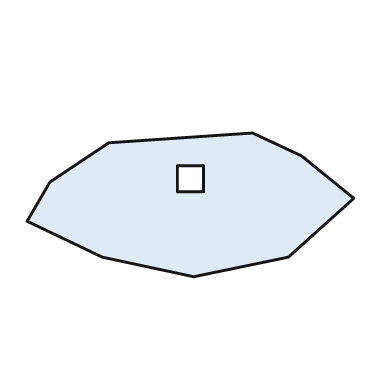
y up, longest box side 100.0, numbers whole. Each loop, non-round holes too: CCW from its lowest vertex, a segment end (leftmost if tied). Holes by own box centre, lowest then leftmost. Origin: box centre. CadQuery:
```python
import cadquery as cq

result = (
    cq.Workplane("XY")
    .moveTo(1.0, -22.0)
    .lineTo(30.0, -16.0)
    .lineTo(50.0, 2.0)
    .lineTo(34.0, 15.0)
    .lineTo(19.0, 22.0)
    .lineTo(-25.0, 19.0)
    .lineTo(-43.0, 7.0)
    .lineTo(-50.0, -5.0)
    .lineTo(-27.0, -16.0)
    .close()
    .moveTo(-4.0, 4.0)
    .lineTo(4.0, 4.0)
    .lineTo(4.0, 12.0)
    .lineTo(-4.0, 12.0)
    .close()
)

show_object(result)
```